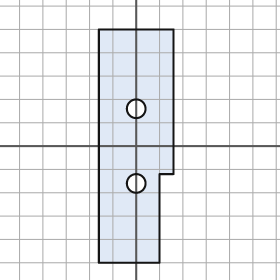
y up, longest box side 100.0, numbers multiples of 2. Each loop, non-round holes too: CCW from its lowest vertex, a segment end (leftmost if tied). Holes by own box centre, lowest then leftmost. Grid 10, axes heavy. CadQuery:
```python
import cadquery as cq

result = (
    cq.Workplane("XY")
    .moveTo(-16.0, -50.0)
    .lineTo(10.0, -50.0)
    .lineTo(10.0, -12.0)
    .lineTo(16.0, -12.0)
    .lineTo(16.0, 50.0)
    .lineTo(-16.0, 50.0)
    .close()
    .moveTo(0.0, -16.0)
    .circle(4.0)
    .moveTo(0.0, 16.0)
    .circle(4.0)
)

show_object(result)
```